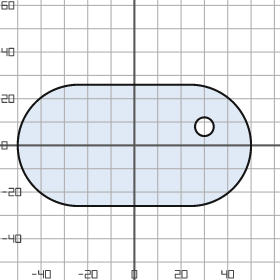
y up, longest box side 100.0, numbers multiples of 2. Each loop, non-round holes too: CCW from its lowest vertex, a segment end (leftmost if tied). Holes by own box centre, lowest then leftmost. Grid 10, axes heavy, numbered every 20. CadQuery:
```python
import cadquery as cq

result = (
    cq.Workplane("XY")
    .moveTo(-24.0, -26.0)
    .lineTo(24.0, -26.0)
    .threePointArc((50.0, 0.0), (24.0, 26.0))
    .lineTo(-24.0, 26.0)
    .threePointArc((-50.0, 0.0), (-24.0, -26.0))
    .close()
    .moveTo(30.0, 8.0)
    .circle(4.0)
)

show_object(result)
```